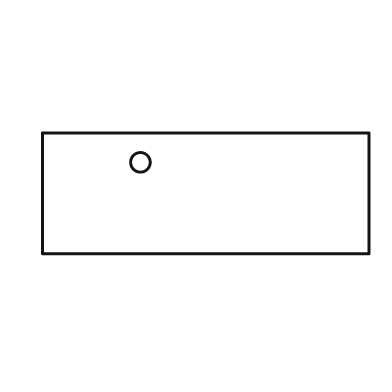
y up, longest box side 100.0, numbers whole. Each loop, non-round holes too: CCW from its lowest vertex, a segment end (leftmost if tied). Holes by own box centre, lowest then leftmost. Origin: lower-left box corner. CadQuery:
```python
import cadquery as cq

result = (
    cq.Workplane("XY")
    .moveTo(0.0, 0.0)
    .lineTo(100.0, 0.0)
    .lineTo(100.0, 37.0)
    .lineTo(0.0, 37.0)
    .close()
    .moveTo(30.0, 28.0)
    .circle(3.0)
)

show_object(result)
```